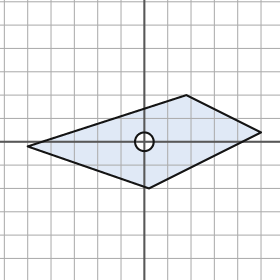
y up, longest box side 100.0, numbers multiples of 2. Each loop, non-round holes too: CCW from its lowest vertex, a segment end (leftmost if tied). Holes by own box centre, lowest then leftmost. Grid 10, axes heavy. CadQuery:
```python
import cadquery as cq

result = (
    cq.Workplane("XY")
    .moveTo(2.0, -20.0)
    .lineTo(50.0, 4.0)
    .lineTo(18.0, 20.0)
    .lineTo(-50.0, -2.0)
    .close()
    .moveTo(0.0, 0.0)
    .circle(4.0)
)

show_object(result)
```